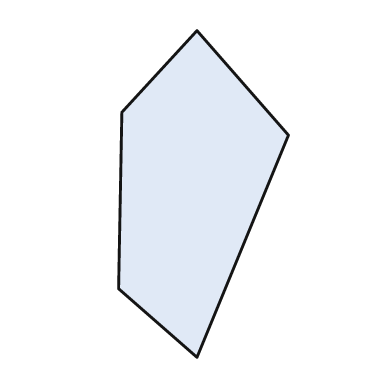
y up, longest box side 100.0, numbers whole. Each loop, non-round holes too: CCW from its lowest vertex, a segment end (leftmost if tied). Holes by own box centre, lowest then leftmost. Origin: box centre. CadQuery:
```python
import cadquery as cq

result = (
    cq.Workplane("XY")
    .moveTo(-2.0, -50.0)
    .lineTo(26.0, 18.0)
    .lineTo(-2.0, 50.0)
    .lineTo(-25.0, 25.0)
    .lineTo(-26.0, -29.0)
    .close()
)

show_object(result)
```